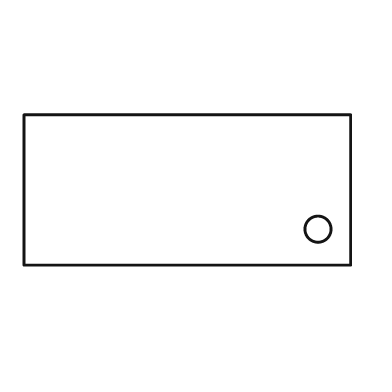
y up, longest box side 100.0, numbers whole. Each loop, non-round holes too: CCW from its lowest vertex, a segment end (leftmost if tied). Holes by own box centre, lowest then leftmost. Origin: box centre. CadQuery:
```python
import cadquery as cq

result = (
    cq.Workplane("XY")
    .moveTo(-50.0, -23.0)
    .lineTo(50.0, -23.0)
    .lineTo(50.0, 23.0)
    .lineTo(-50.0, 23.0)
    .close()
    .moveTo(40.0, -12.0)
    .circle(4.0)
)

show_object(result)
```